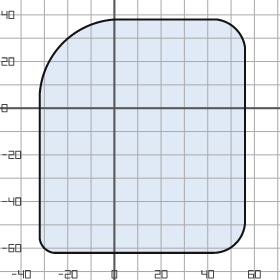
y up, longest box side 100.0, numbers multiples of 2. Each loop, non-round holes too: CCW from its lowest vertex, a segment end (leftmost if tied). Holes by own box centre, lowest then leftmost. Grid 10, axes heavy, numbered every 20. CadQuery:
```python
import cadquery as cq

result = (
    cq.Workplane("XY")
    .moveTo(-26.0, -62.0)
    .lineTo(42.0, -62.0)
    .threePointArc((52.0, -58.0), (56.0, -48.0))
    .lineTo(56.0, 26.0)
    .threePointArc((52.0, 34.0), (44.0, 38.0))
    .lineTo(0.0, 38.0)
    .threePointArc((-22.0, 28.0), (-32.0, 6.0))
    .lineTo(-32.0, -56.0)
    .threePointArc((-30.0, -60.0), (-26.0, -62.0))
    .close()
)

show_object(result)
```